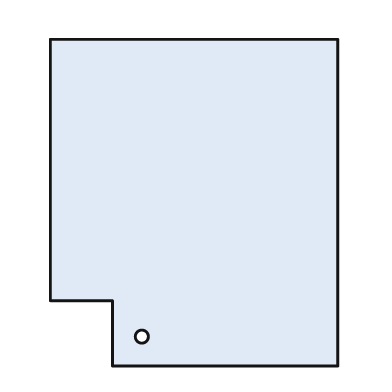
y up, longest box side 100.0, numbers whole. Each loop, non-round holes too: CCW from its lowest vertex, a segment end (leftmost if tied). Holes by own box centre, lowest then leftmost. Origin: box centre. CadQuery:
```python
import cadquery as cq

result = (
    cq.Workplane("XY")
    .moveTo(-25.0, -50.0)
    .lineTo(44.0, -50.0)
    .lineTo(44.0, 50.0)
    .lineTo(-44.0, 50.0)
    .lineTo(-44.0, -30.0)
    .lineTo(-25.0, -30.0)
    .close()
    .moveTo(-16.0, -41.0)
    .circle(2.0)
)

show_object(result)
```